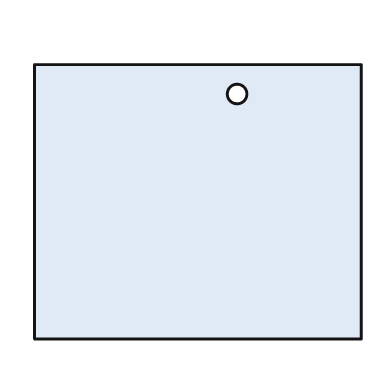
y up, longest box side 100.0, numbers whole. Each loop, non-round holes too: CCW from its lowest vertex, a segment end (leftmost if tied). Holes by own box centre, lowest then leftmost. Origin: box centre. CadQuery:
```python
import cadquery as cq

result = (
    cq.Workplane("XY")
    .moveTo(-50.0, -42.0)
    .lineTo(50.0, -42.0)
    .lineTo(50.0, 42.0)
    .lineTo(-50.0, 42.0)
    .close()
    .moveTo(12.0, 33.0)
    .circle(3.0)
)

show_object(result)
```